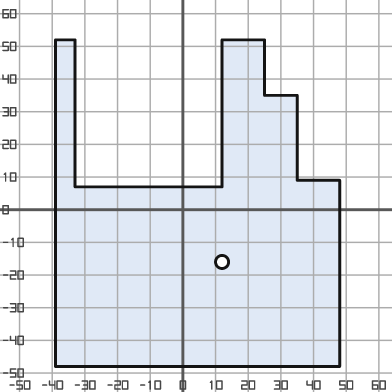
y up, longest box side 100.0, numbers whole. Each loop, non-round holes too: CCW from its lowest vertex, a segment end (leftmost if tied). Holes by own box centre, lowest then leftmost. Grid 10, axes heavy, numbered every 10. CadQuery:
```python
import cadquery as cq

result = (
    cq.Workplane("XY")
    .moveTo(-39.0, -48.0)
    .lineTo(48.0, -48.0)
    .lineTo(48.0, 9.0)
    .lineTo(35.0, 9.0)
    .lineTo(35.0, 35.0)
    .lineTo(25.0, 35.0)
    .lineTo(25.0, 52.0)
    .lineTo(12.0, 52.0)
    .lineTo(12.0, 7.0)
    .lineTo(-33.0, 7.0)
    .lineTo(-33.0, 52.0)
    .lineTo(-39.0, 52.0)
    .close()
    .moveTo(12.0, -16.0)
    .circle(2.0)
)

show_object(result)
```